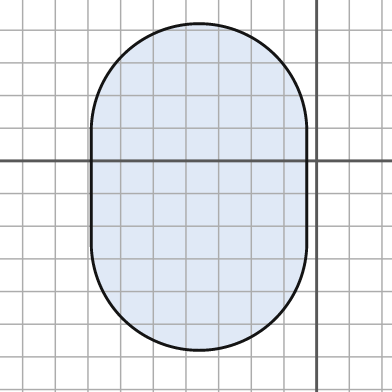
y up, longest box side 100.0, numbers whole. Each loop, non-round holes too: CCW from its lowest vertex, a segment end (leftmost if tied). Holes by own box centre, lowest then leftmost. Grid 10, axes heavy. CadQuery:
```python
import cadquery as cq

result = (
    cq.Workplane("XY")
    .moveTo(-69.0, -25.0)
    .threePointArc((-36.0, -58.0), (-3.0, -25.0))
    .lineTo(-3.0, 9.0)
    .threePointArc((-36.0, 42.0), (-69.0, 9.0))
    .close()
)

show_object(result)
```